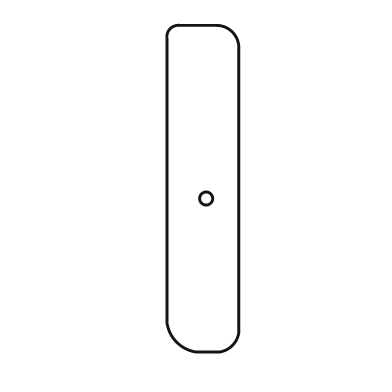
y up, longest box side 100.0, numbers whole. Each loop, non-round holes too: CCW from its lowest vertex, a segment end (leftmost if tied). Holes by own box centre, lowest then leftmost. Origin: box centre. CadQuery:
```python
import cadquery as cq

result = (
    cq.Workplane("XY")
    .moveTo(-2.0, -50.0)
    .lineTo(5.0, -50.0)
    .threePointArc((9.0, -48.0), (11.0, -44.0))
    .lineTo(11.0, 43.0)
    .threePointArc((9.0, 48.0), (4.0, 50.0))
    .lineTo(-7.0, 50.0)
    .threePointArc((-10.0, 49.0), (-11.0, 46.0))
    .lineTo(-11.0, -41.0)
    .threePointArc((-8.0, -47.0), (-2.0, -50.0))
    .close()
    .moveTo(1.0, -3.0)
    .circle(2.0)
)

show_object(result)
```